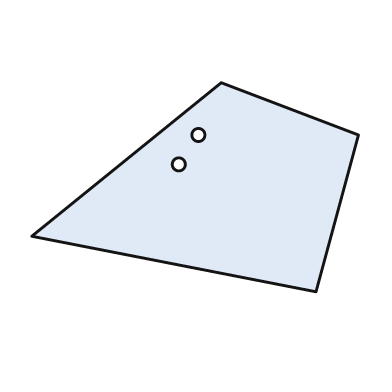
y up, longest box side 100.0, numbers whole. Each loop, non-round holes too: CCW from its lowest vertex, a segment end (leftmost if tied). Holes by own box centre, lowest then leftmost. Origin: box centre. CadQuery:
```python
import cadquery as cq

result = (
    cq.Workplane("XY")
    .moveTo(37.0, -32.0)
    .lineTo(50.0, 16.0)
    .lineTo(8.0, 32.0)
    .lineTo(-50.0, -15.0)
    .close()
    .moveTo(-5.0, 7.0)
    .circle(2.0)
    .moveTo(1.0, 16.0)
    .circle(2.0)
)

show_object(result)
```